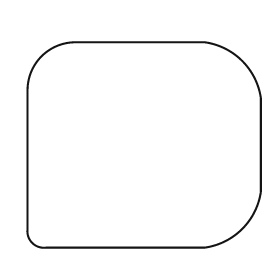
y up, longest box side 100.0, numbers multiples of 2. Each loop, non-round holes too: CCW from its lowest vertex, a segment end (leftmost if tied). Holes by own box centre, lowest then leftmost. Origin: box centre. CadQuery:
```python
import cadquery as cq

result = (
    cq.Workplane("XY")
    .moveTo(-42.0, -44.0)
    .lineTo(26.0, -44.0)
    .threePointArc((42.0, -36.0), (50.0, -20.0))
    .lineTo(50.0, 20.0)
    .threePointArc((42.0, 36.0), (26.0, 44.0))
    .lineTo(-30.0, 44.0)
    .threePointArc((-44.0, 38.0), (-50.0, 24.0))
    .lineTo(-50.0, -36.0)
    .threePointArc((-48.0, -42.0), (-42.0, -44.0))
    .close()
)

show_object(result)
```